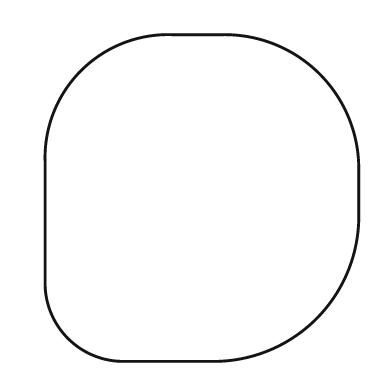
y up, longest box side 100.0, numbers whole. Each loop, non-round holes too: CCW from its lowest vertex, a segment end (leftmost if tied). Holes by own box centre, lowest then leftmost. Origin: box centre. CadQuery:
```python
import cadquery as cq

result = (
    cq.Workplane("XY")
    .moveTo(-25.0, -50.0)
    .lineTo(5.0, -50.0)
    .threePointArc((35.0, -37.0), (48.0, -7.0))
    .lineTo(48.0, 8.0)
    .threePointArc((36.0, 38.0), (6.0, 50.0))
    .lineTo(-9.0, 50.0)
    .threePointArc((-37.0, 39.0), (-48.0, 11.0))
    .lineTo(-48.0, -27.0)
    .threePointArc((-41.0, -43.0), (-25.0, -50.0))
    .close()
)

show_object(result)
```